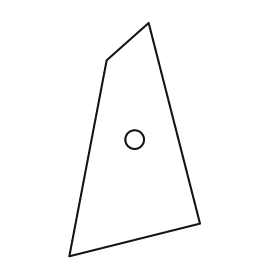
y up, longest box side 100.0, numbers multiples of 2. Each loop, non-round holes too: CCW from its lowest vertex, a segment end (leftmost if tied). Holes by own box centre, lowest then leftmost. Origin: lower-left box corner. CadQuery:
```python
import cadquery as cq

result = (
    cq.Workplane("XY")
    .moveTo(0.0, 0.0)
    .lineTo(56.0, 14.0)
    .lineTo(34.0, 100.0)
    .lineTo(16.0, 84.0)
    .close()
    .moveTo(28.0, 50.0)
    .circle(4.0)
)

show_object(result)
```